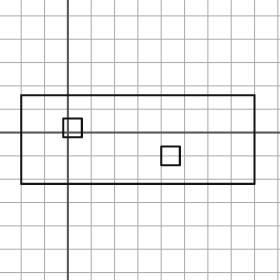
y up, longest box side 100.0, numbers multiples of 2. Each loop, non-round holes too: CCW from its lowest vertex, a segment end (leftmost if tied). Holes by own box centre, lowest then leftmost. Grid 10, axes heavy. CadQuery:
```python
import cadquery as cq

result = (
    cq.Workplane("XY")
    .moveTo(-20.0, -22.0)
    .lineTo(80.0, -22.0)
    .lineTo(80.0, 16.0)
    .lineTo(-20.0, 16.0)
    .close()
    .moveTo(40.0, -14.0)
    .lineTo(48.0, -14.0)
    .lineTo(48.0, -6.0)
    .lineTo(40.0, -6.0)
    .close()
    .moveTo(-2.0, -2.0)
    .lineTo(6.0, -2.0)
    .lineTo(6.0, 6.0)
    .lineTo(-2.0, 6.0)
    .close()
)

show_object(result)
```